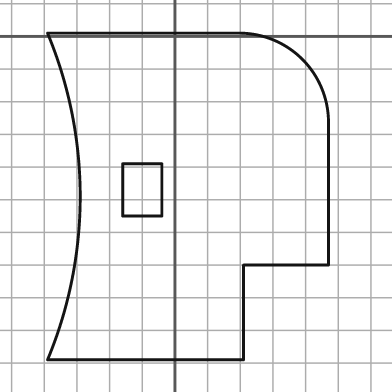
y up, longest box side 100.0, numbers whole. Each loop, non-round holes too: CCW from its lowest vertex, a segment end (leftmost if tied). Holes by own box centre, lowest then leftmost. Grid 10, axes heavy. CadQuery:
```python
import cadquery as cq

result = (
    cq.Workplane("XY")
    .moveTo(-39.0, -99.0)
    .lineTo(21.0, -99.0)
    .lineTo(21.0, -70.0)
    .lineTo(47.0, -70.0)
    .lineTo(47.0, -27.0)
    .threePointArc((39.0, -7.0), (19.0, 1.0))
    .lineTo(-39.0, 1.0)
    .threePointArc((-29.0, -49.0), (-39.0, -99.0))
    .close()
    .moveTo(-16.0, -55.0)
    .lineTo(-4.0, -55.0)
    .lineTo(-4.0, -39.0)
    .lineTo(-16.0, -39.0)
    .close()
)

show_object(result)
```